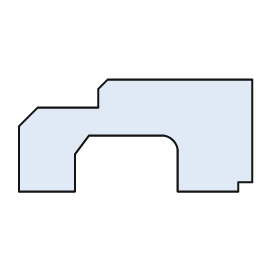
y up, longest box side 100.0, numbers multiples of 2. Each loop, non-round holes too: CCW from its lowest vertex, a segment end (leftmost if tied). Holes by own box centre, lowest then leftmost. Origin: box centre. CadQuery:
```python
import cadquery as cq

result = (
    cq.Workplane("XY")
    .moveTo(-50.0, -24.0)
    .lineTo(-26.0, -24.0)
    .lineTo(-26.0, -8.0)
    .lineTo(-20.0, 0.0)
    .lineTo(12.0, 0.0)
    .threePointArc((16.0, -2.0), (18.0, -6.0))
    .lineTo(18.0, -24.0)
    .lineTo(44.0, -24.0)
    .lineTo(44.0, -20.0)
    .lineTo(50.0, -20.0)
    .lineTo(50.0, 24.0)
    .lineTo(-12.0, 24.0)
    .lineTo(-16.0, 20.0)
    .lineTo(-16.0, 12.0)
    .lineTo(-42.0, 12.0)
    .lineTo(-50.0, 4.0)
    .close()
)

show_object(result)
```